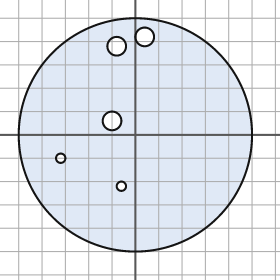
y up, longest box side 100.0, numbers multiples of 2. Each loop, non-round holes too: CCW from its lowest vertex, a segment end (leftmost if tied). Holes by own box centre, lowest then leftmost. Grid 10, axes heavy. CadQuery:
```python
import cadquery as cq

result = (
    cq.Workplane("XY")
    .moveTo(0.0, 0.0)
    .circle(50.0)
    .moveTo(-6.0, -22.0)
    .circle(2.0)
    .moveTo(-32.0, -10.0)
    .circle(2.0)
    .moveTo(-10.0, 6.0)
    .circle(4.0)
    .moveTo(-8.0, 38.0)
    .circle(4.0)
    .moveTo(4.0, 42.0)
    .circle(4.0)
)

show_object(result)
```